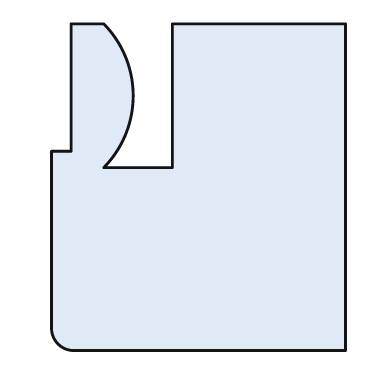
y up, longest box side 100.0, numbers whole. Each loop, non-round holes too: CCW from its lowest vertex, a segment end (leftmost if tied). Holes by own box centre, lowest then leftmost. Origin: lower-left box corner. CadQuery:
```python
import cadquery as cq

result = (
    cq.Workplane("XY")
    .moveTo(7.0, 0.0)
    .lineTo(90.0, 0.0)
    .lineTo(90.0, 100.0)
    .lineTo(37.0, 100.0)
    .lineTo(37.0, 56.0)
    .lineTo(16.0, 56.0)
    .threePointArc((25.0, 78.0), (16.0, 100.0))
    .lineTo(6.0, 100.0)
    .lineTo(6.0, 61.0)
    .lineTo(0.0, 61.0)
    .lineTo(0.0, 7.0)
    .threePointArc((2.0, 2.0), (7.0, 0.0))
    .close()
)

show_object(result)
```